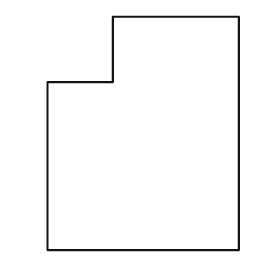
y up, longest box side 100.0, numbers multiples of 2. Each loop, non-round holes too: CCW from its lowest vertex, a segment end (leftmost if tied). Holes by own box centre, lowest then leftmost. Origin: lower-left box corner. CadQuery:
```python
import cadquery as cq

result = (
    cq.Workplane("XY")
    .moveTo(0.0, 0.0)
    .lineTo(82.0, 0.0)
    .lineTo(82.0, 100.0)
    .lineTo(28.0, 100.0)
    .lineTo(28.0, 72.0)
    .lineTo(0.0, 72.0)
    .close()
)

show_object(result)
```